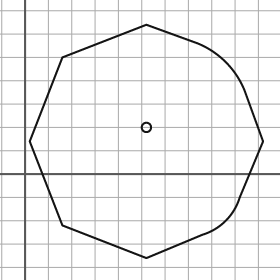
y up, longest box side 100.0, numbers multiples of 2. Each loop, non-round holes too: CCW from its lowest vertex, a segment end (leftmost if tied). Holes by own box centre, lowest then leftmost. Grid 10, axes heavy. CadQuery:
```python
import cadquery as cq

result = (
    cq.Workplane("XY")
    .moveTo(52.0, -36.0)
    .lineTo(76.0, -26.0)
    .threePointArc((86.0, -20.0), (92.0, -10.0))
    .lineTo(102.0, 14.0)
    .lineTo(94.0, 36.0)
    .threePointArc((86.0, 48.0), (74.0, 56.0))
    .lineTo(52.0, 64.0)
    .lineTo(16.0, 50.0)
    .lineTo(2.0, 14.0)
    .lineTo(16.0, -22.0)
    .close()
    .moveTo(52.0, 20.0)
    .circle(2.0)
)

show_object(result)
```